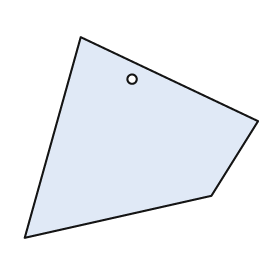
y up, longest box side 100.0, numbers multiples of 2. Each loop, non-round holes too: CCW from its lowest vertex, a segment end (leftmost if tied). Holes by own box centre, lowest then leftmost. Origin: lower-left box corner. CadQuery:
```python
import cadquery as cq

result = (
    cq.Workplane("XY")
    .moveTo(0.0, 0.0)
    .lineTo(80.0, 18.0)
    .lineTo(100.0, 50.0)
    .lineTo(24.0, 86.0)
    .close()
    .moveTo(46.0, 68.0)
    .circle(2.0)
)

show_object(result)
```